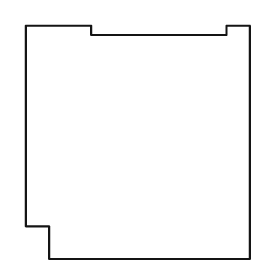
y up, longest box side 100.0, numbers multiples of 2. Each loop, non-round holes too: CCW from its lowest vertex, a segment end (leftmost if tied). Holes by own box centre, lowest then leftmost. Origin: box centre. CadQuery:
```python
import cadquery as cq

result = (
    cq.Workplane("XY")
    .moveTo(-38.0, -50.0)
    .lineTo(48.0, -50.0)
    .lineTo(48.0, 50.0)
    .lineTo(38.0, 50.0)
    .lineTo(38.0, 46.0)
    .lineTo(-20.0, 46.0)
    .lineTo(-20.0, 50.0)
    .lineTo(-48.0, 50.0)
    .lineTo(-48.0, -36.0)
    .lineTo(-38.0, -36.0)
    .close()
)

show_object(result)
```